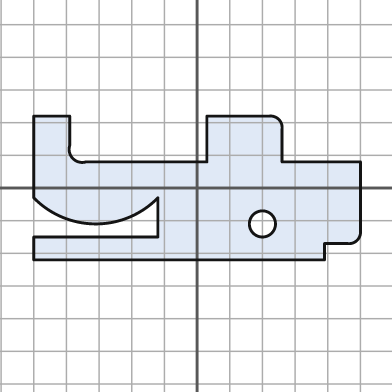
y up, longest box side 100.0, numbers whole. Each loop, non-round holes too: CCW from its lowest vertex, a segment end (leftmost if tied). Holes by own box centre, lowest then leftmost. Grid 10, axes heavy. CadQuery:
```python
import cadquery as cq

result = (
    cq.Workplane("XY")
    .moveTo(-50.0, -22.0)
    .lineTo(39.0, -22.0)
    .lineTo(39.0, -17.0)
    .lineTo(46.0, -17.0)
    .threePointArc((49.0, -16.0), (50.0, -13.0))
    .lineTo(50.0, 8.0)
    .lineTo(26.0, 8.0)
    .lineTo(26.0, 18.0)
    .threePointArc((25.0, 21.0), (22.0, 22.0))
    .lineTo(3.0, 22.0)
    .lineTo(3.0, 8.0)
    .lineTo(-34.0, 8.0)
    .threePointArc((-38.0, 9.0), (-39.0, 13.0))
    .lineTo(-39.0, 22.0)
    .lineTo(-50.0, 22.0)
    .lineTo(-50.0, -3.0)
    .threePointArc((-31.0, -11.0), (-12.0, -3.0))
    .lineTo(-12.0, -15.0)
    .lineTo(-50.0, -15.0)
    .close()
    .moveTo(20.0, -11.0)
    .circle(4.0)
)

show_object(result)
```